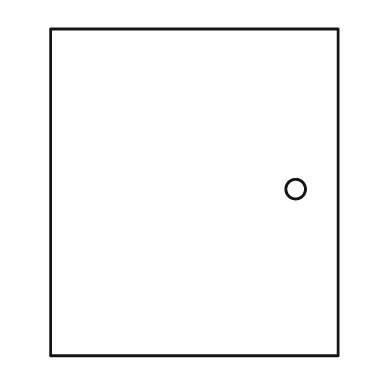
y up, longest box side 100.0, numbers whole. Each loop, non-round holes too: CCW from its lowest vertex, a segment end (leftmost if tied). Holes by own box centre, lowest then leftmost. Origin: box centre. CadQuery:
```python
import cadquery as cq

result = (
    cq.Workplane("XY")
    .moveTo(-44.0, -50.0)
    .lineTo(44.0, -50.0)
    .lineTo(44.0, 50.0)
    .lineTo(-44.0, 50.0)
    .close()
    .moveTo(31.0, 1.0)
    .circle(3.0)
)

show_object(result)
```